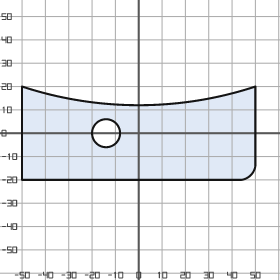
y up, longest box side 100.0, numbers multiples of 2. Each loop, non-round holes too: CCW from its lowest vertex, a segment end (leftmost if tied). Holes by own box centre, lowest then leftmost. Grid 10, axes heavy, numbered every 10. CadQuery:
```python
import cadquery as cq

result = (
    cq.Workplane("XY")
    .moveTo(-50.0, -20.0)
    .lineTo(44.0, -20.0)
    .threePointArc((48.0, -18.0), (50.0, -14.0))
    .lineTo(50.0, 20.0)
    .threePointArc((0.0, 12.0), (-50.0, 20.0))
    .close()
    .moveTo(-14.0, 0.0)
    .circle(6.0)
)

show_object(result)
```